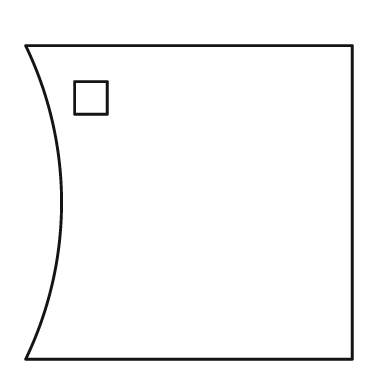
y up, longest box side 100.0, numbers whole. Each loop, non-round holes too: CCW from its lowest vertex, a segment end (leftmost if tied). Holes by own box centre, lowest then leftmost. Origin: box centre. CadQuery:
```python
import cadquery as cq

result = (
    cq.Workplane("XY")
    .moveTo(-50.0, -48.0)
    .lineTo(50.0, -48.0)
    .lineTo(50.0, 48.0)
    .lineTo(-50.0, 48.0)
    .threePointArc((-39.0, 0.0), (-50.0, -48.0))
    .close()
    .moveTo(-35.0, 27.0)
    .lineTo(-25.0, 27.0)
    .lineTo(-25.0, 37.0)
    .lineTo(-35.0, 37.0)
    .close()
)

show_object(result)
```